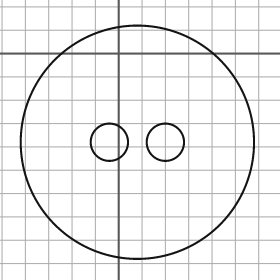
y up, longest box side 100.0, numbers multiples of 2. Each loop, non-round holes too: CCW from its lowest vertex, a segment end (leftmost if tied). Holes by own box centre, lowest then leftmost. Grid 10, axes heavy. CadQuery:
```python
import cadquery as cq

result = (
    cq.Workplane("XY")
    .moveTo(8.0, -38.0)
    .circle(50.0)
    .moveTo(-4.0, -38.0)
    .circle(8.0)
    .moveTo(20.0, -38.0)
    .circle(8.0)
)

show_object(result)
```